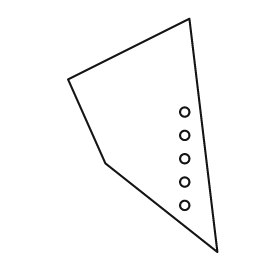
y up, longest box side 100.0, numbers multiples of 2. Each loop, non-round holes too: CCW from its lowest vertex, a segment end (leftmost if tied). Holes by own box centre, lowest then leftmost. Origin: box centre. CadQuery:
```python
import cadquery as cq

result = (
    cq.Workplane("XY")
    .moveTo(32.0, -50.0)
    .lineTo(20.0, 50.0)
    .lineTo(-32.0, 24.0)
    .lineTo(-16.0, -12.0)
    .close()
    .moveTo(18.0, -30.0)
    .circle(2.0)
    .moveTo(18.0, -20.0)
    .circle(2.0)
    .moveTo(18.0, -10.0)
    .circle(2.0)
    .moveTo(18.0, 0.0)
    .circle(2.0)
    .moveTo(18.0, 10.0)
    .circle(2.0)
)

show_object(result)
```